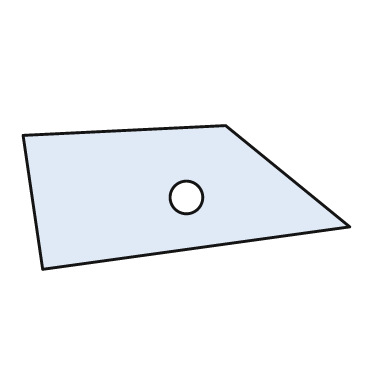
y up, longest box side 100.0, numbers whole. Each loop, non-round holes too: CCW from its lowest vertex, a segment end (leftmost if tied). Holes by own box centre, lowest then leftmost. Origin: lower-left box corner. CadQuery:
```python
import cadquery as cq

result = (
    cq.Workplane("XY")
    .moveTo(6.0, 0.0)
    .lineTo(100.0, 13.0)
    .lineTo(62.0, 44.0)
    .lineTo(0.0, 41.0)
    .close()
    .moveTo(50.0, 22.0)
    .circle(5.0)
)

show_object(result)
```